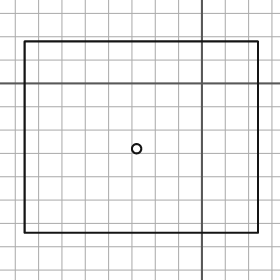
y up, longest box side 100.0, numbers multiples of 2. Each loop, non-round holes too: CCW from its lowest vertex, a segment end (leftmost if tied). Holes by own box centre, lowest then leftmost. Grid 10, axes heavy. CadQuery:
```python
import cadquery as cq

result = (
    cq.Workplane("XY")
    .moveTo(-76.0, -64.0)
    .lineTo(24.0, -64.0)
    .lineTo(24.0, 18.0)
    .lineTo(-76.0, 18.0)
    .close()
    .moveTo(-28.0, -28.0)
    .circle(2.0)
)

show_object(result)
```